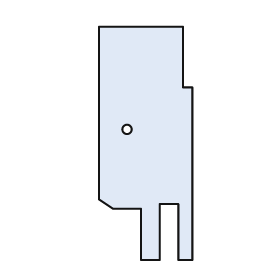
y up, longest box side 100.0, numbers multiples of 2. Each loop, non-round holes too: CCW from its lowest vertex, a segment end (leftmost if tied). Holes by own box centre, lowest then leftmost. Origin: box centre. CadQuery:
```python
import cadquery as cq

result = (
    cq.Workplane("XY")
    .moveTo(-2.0, -50.0)
    .lineTo(6.0, -50.0)
    .lineTo(6.0, -26.0)
    .lineTo(14.0, -26.0)
    .lineTo(14.0, -50.0)
    .lineTo(20.0, -50.0)
    .lineTo(20.0, 24.0)
    .lineTo(16.0, 24.0)
    .lineTo(16.0, 50.0)
    .lineTo(-20.0, 50.0)
    .lineTo(-20.0, -24.0)
    .lineTo(-14.0, -28.0)
    .lineTo(-2.0, -28.0)
    .close()
    .moveTo(-8.0, 6.0)
    .circle(2.0)
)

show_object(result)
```